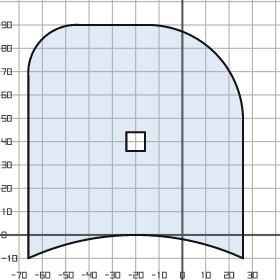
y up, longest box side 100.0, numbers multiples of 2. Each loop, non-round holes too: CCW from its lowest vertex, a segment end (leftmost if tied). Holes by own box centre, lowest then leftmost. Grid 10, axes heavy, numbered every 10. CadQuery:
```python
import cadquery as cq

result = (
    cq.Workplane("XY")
    .moveTo(-66.0, -10.0)
    .threePointArc((-20.0, 0.0), (26.0, -10.0))
    .lineTo(26.0, 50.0)
    .threePointArc((14.0, 78.0), (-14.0, 90.0))
    .lineTo(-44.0, 90.0)
    .threePointArc((-60.0, 84.0), (-66.0, 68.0))
    .close()
    .moveTo(-24.0, 36.0)
    .lineTo(-16.0, 36.0)
    .lineTo(-16.0, 44.0)
    .lineTo(-24.0, 44.0)
    .close()
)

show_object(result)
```